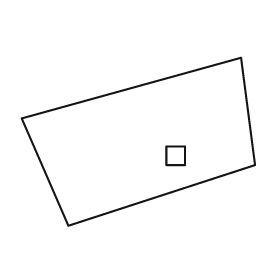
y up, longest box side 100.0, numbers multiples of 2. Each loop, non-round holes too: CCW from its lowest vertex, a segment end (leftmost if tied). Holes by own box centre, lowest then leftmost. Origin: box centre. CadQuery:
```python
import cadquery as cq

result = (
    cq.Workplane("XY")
    .moveTo(-30.0, -36.0)
    .lineTo(50.0, -10.0)
    .lineTo(44.0, 36.0)
    .lineTo(-50.0, 10.0)
    .close()
    .moveTo(12.0, -10.0)
    .lineTo(20.0, -10.0)
    .lineTo(20.0, -2.0)
    .lineTo(12.0, -2.0)
    .close()
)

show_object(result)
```